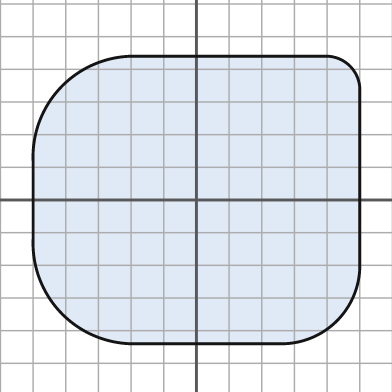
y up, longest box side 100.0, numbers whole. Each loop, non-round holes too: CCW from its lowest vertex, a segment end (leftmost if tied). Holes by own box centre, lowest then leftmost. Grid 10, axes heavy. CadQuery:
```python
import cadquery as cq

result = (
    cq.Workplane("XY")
    .moveTo(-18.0, -44.0)
    .lineTo(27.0, -44.0)
    .threePointArc((43.0, -37.0), (50.0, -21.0))
    .lineTo(50.0, 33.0)
    .threePointArc((47.0, 41.0), (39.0, 44.0))
    .lineTo(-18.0, 44.0)
    .threePointArc((-41.0, 35.0), (-50.0, 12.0))
    .lineTo(-50.0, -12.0)
    .threePointArc((-41.0, -35.0), (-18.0, -44.0))
    .close()
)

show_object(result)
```